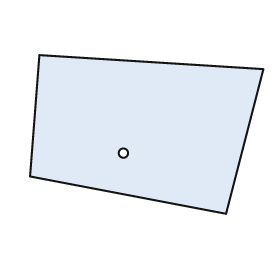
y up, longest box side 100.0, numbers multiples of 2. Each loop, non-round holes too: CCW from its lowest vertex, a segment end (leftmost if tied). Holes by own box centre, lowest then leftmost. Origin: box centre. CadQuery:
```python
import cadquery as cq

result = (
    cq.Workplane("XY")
    .moveTo(34.0, -34.0)
    .lineTo(50.0, 28.0)
    .lineTo(-46.0, 34.0)
    .lineTo(-50.0, -18.0)
    .close()
    .moveTo(-10.0, -8.0)
    .circle(2.0)
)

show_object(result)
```